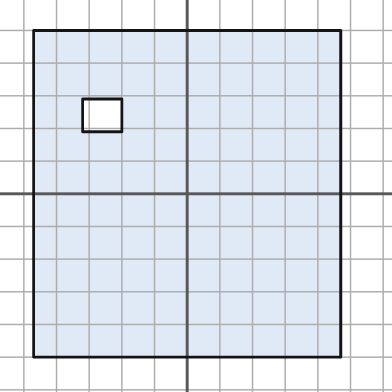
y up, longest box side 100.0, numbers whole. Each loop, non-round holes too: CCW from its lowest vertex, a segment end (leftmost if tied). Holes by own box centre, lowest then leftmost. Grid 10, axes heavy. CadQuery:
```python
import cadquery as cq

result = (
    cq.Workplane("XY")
    .moveTo(-47.0, -50.0)
    .lineTo(47.0, -50.0)
    .lineTo(47.0, 50.0)
    .lineTo(-47.0, 50.0)
    .close()
    .moveTo(-32.0, 19.0)
    .lineTo(-20.0, 19.0)
    .lineTo(-20.0, 29.0)
    .lineTo(-32.0, 29.0)
    .close()
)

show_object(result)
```